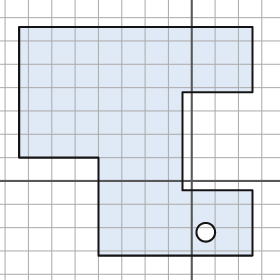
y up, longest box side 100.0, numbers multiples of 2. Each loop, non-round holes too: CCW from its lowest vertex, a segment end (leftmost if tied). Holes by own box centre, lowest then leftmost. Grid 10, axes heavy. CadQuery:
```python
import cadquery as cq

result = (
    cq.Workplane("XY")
    .moveTo(-40.0, -32.0)
    .lineTo(26.0, -32.0)
    .lineTo(26.0, -4.0)
    .lineTo(-4.0, -4.0)
    .lineTo(-4.0, 38.0)
    .lineTo(26.0, 38.0)
    .lineTo(26.0, 66.0)
    .lineTo(-74.0, 66.0)
    .lineTo(-74.0, 10.0)
    .lineTo(-40.0, 10.0)
    .close()
    .moveTo(6.0, -22.0)
    .circle(4.0)
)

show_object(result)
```